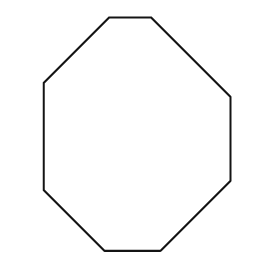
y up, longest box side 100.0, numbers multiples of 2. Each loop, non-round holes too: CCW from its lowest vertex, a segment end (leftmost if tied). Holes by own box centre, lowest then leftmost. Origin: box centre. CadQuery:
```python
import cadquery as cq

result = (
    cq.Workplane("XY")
    .moveTo(-14.0, -50.0)
    .lineTo(10.0, -50.0)
    .lineTo(40.0, -20.0)
    .lineTo(40.0, 16.0)
    .lineTo(6.0, 50.0)
    .lineTo(-12.0, 50.0)
    .lineTo(-40.0, 22.0)
    .lineTo(-40.0, -24.0)
    .close()
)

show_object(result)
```